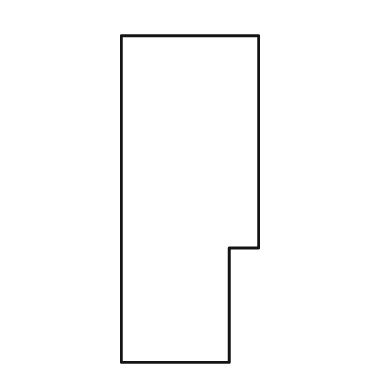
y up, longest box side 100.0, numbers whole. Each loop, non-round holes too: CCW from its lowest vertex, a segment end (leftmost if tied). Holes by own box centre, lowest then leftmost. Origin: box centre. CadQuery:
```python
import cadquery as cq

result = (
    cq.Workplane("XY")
    .moveTo(-21.0, -50.0)
    .lineTo(12.0, -50.0)
    .lineTo(12.0, -15.0)
    .lineTo(21.0, -15.0)
    .lineTo(21.0, 50.0)
    .lineTo(-21.0, 50.0)
    .close()
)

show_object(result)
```